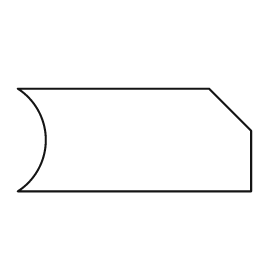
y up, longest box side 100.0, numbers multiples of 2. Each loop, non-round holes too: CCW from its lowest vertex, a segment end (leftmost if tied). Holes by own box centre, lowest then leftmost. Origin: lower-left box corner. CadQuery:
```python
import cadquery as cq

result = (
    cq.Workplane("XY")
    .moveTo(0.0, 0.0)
    .lineTo(100.0, 0.0)
    .lineTo(100.0, 26.0)
    .lineTo(82.0, 44.0)
    .lineTo(0.0, 44.0)
    .threePointArc((12.0, 22.0), (0.0, 0.0))
    .close()
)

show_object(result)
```